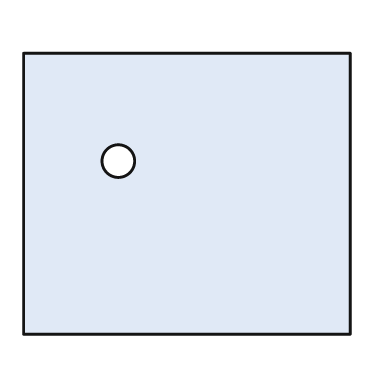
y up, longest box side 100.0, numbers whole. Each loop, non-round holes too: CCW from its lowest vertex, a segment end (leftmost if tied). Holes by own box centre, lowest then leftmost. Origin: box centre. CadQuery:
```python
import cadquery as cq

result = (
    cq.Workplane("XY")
    .moveTo(-50.0, -43.0)
    .lineTo(50.0, -43.0)
    .lineTo(50.0, 43.0)
    .lineTo(-50.0, 43.0)
    .close()
    .moveTo(-21.0, 10.0)
    .circle(5.0)
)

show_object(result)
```